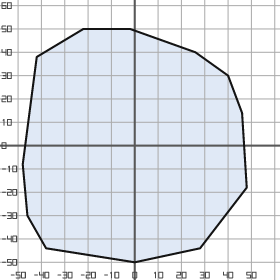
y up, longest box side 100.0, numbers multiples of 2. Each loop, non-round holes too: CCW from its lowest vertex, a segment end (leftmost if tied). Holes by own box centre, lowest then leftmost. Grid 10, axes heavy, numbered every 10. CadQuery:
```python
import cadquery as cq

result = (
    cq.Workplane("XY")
    .moveTo(0.0, -50.0)
    .lineTo(28.0, -44.0)
    .lineTo(48.0, -18.0)
    .lineTo(46.0, 14.0)
    .lineTo(40.0, 30.0)
    .lineTo(26.0, 40.0)
    .lineTo(-2.0, 50.0)
    .lineTo(-22.0, 50.0)
    .lineTo(-42.0, 38.0)
    .lineTo(-48.0, -8.0)
    .lineTo(-46.0, -30.0)
    .lineTo(-38.0, -44.0)
    .close()
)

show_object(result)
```